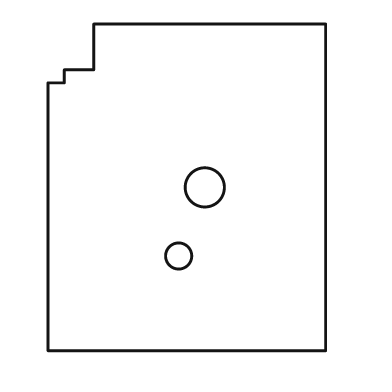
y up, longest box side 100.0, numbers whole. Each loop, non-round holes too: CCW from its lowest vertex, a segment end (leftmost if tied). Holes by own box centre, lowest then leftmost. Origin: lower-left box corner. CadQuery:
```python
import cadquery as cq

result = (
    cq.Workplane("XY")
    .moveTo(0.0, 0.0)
    .lineTo(85.0, 0.0)
    .lineTo(85.0, 100.0)
    .lineTo(14.0, 100.0)
    .lineTo(14.0, 86.0)
    .lineTo(5.0, 86.0)
    .lineTo(5.0, 82.0)
    .lineTo(0.0, 82.0)
    .close()
    .moveTo(40.0, 29.0)
    .circle(4.0)
    .moveTo(48.0, 50.0)
    .circle(6.0)
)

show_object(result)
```